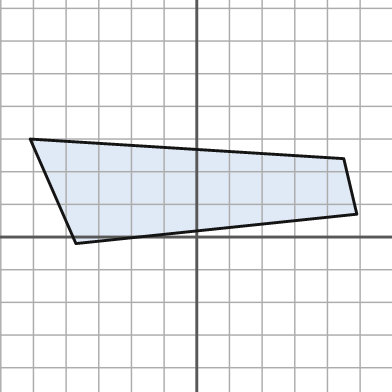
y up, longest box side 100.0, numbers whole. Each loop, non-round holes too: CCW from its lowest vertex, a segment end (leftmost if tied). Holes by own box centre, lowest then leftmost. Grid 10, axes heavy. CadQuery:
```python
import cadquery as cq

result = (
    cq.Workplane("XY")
    .moveTo(-37.0, -2.0)
    .lineTo(49.0, 7.0)
    .lineTo(45.0, 24.0)
    .lineTo(-51.0, 30.0)
    .close()
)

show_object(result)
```